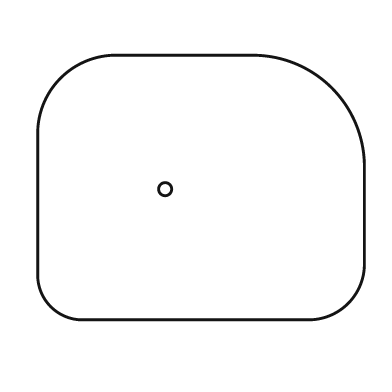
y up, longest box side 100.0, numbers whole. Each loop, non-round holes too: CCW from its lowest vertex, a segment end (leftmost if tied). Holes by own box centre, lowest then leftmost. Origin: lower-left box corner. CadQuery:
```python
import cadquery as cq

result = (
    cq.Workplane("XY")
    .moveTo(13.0, 0.0)
    .lineTo(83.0, 0.0)
    .threePointArc((95.0, 5.0), (100.0, 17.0))
    .lineTo(100.0, 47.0)
    .threePointArc((90.0, 71.0), (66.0, 81.0))
    .lineTo(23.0, 81.0)
    .threePointArc((7.0, 74.0), (0.0, 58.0))
    .lineTo(0.0, 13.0)
    .threePointArc((4.0, 4.0), (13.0, 0.0))
    .close()
    .moveTo(39.0, 40.0)
    .circle(2.0)
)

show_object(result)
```